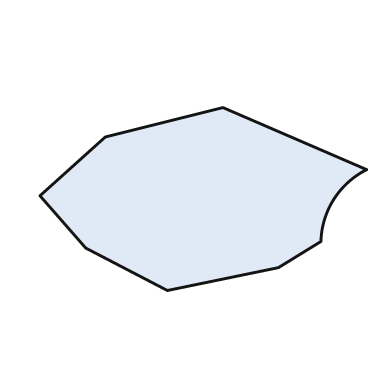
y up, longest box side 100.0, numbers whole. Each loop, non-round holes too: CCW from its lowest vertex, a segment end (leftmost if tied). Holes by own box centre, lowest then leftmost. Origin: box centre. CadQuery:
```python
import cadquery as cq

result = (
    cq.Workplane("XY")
    .moveTo(-11.0, -28.0)
    .lineTo(23.0, -21.0)
    .lineTo(36.0, -13.0)
    .threePointArc((40.0, 0.0), (50.0, 9.0))
    .lineTo(6.0, 28.0)
    .lineTo(-30.0, 19.0)
    .lineTo(-50.0, 1.0)
    .lineTo(-36.0, -15.0)
    .close()
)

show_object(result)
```